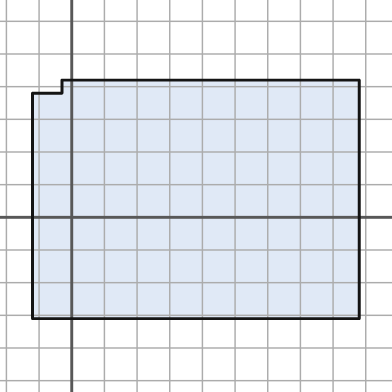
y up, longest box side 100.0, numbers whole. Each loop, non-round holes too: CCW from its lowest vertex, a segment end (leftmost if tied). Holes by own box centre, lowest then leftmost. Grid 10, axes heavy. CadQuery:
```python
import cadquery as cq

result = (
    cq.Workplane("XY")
    .moveTo(-12.0, -31.0)
    .lineTo(88.0, -31.0)
    .lineTo(88.0, 42.0)
    .lineTo(-3.0, 42.0)
    .lineTo(-3.0, 38.0)
    .lineTo(-12.0, 38.0)
    .close()
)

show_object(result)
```